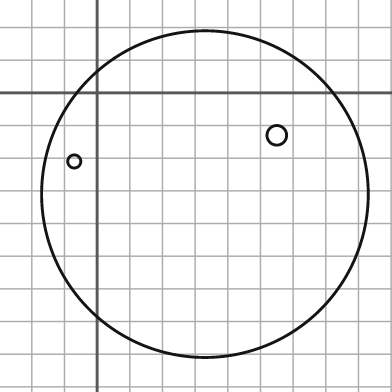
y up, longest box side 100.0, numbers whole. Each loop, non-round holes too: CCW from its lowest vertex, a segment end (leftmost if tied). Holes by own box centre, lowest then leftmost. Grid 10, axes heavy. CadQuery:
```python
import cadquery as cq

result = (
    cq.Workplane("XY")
    .moveTo(33.0, -31.0)
    .circle(50.0)
    .moveTo(-7.0, -21.0)
    .circle(2.0)
    .moveTo(55.0, -13.0)
    .circle(3.0)
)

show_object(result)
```